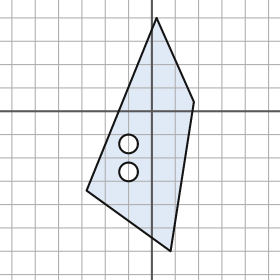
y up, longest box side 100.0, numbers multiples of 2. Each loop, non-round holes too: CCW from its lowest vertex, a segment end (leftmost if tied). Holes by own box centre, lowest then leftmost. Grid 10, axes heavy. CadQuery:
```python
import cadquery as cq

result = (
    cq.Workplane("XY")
    .moveTo(8.0, -60.0)
    .lineTo(18.0, 4.0)
    .lineTo(2.0, 40.0)
    .lineTo(-28.0, -34.0)
    .close()
    .moveTo(-10.0, -26.0)
    .circle(4.0)
    .moveTo(-10.0, -14.0)
    .circle(4.0)
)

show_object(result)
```